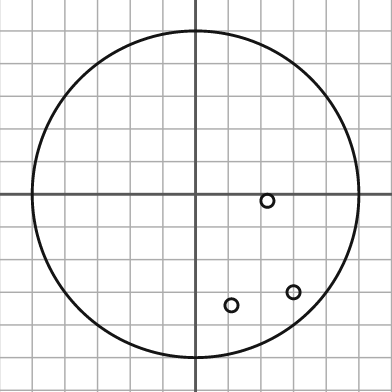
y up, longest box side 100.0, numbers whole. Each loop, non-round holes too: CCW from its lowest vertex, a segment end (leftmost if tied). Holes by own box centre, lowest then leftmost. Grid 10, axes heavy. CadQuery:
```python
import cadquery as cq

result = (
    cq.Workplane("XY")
    .moveTo(0.0, 0.0)
    .circle(50.0)
    .moveTo(11.0, -34.0)
    .circle(2.0)
    .moveTo(30.0, -30.0)
    .circle(2.0)
    .moveTo(22.0, -2.0)
    .circle(2.0)
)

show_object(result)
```